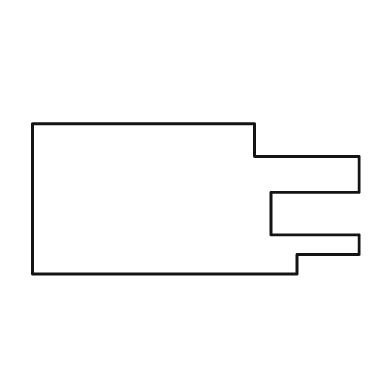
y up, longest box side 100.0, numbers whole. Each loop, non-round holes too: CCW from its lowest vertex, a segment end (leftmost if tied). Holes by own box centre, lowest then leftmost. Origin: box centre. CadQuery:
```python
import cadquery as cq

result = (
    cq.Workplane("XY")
    .moveTo(-50.0, -23.0)
    .lineTo(31.0, -23.0)
    .lineTo(31.0, -17.0)
    .lineTo(50.0, -17.0)
    .lineTo(50.0, -11.0)
    .lineTo(23.0, -11.0)
    .lineTo(23.0, 2.0)
    .lineTo(50.0, 2.0)
    .lineTo(50.0, 13.0)
    .lineTo(18.0, 13.0)
    .lineTo(18.0, 23.0)
    .lineTo(-50.0, 23.0)
    .close()
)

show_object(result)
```